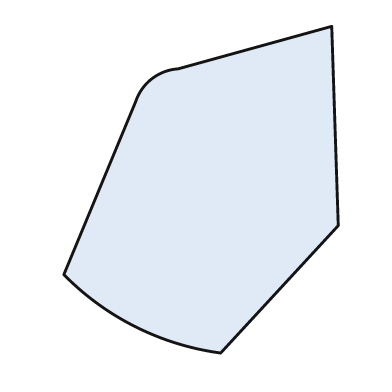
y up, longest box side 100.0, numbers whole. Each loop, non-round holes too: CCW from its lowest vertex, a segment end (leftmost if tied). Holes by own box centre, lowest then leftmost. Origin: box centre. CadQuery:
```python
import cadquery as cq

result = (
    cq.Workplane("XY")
    .moveTo(6.0, -50.0)
    .lineTo(42.0, -11.0)
    .lineTo(40.0, 50.0)
    .lineTo(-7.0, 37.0)
    .threePointArc((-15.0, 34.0), (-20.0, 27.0))
    .lineTo(-42.0, -26.0)
    .threePointArc((-20.0, -42.0), (6.0, -50.0))
    .close()
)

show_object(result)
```